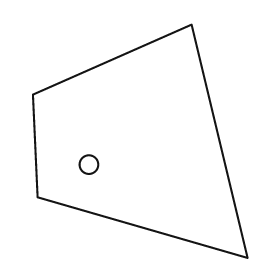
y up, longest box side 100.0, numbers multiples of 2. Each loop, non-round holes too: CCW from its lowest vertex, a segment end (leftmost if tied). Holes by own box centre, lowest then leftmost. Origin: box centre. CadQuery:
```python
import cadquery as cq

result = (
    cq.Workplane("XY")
    .moveTo(46.0, -50.0)
    .lineTo(22.0, 50.0)
    .lineTo(-46.0, 20.0)
    .lineTo(-44.0, -24.0)
    .close()
    .moveTo(-22.0, -10.0)
    .circle(4.0)
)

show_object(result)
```